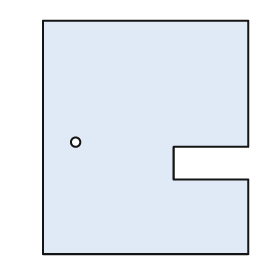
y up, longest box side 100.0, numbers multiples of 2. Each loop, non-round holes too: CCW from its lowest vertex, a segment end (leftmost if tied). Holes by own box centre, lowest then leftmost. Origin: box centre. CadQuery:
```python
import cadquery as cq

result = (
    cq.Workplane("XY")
    .moveTo(-44.0, -50.0)
    .lineTo(44.0, -50.0)
    .lineTo(44.0, -18.0)
    .lineTo(12.0, -18.0)
    .lineTo(12.0, -4.0)
    .lineTo(44.0, -4.0)
    .lineTo(44.0, 50.0)
    .lineTo(-44.0, 50.0)
    .close()
    .moveTo(-30.0, -2.0)
    .circle(2.0)
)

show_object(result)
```